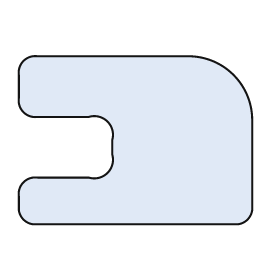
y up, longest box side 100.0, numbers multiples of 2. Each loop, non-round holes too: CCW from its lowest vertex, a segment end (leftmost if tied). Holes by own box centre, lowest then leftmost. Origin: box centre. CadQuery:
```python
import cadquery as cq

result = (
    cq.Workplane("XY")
    .moveTo(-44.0, -36.0)
    .lineTo(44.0, -36.0)
    .threePointArc((48.0, -34.0), (50.0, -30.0))
    .lineTo(50.0, 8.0)
    .threePointArc((42.0, 28.0), (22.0, 36.0))
    .lineTo(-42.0, 36.0)
    .threePointArc((-48.0, 34.0), (-50.0, 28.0))
    .lineTo(-50.0, 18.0)
    .threePointArc((-48.0, 12.0), (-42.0, 10.0))
    .lineTo(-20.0, 10.0)
    .threePointArc((-12.0, 8.0), (-10.0, 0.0))
    .lineTo(-10.0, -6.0)
    .threePointArc((-12.0, -14.0), (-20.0, -16.0))
    .lineTo(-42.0, -16.0)
    .threePointArc((-48.0, -18.0), (-50.0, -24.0))
    .lineTo(-50.0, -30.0)
    .threePointArc((-48.0, -34.0), (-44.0, -36.0))
    .close()
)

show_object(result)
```